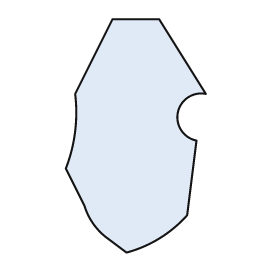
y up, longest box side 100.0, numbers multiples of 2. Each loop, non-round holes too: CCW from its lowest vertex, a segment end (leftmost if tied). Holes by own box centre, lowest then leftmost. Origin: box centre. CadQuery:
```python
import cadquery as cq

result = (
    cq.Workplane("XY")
    .moveTo(-4.0, -50.0)
    .threePointArc((10.0, -44.0), (22.0, -34.0))
    .lineTo(26.0, -2.0)
    .threePointArc((18.0, 10.0), (30.0, 18.0))
    .lineTo(10.0, 50.0)
    .lineTo(-10.0, 50.0)
    .lineTo(-26.0, 18.0)
    .threePointArc((-26.0, 2.0), (-30.0, -14.0))
    .lineTo(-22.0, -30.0)
    .threePointArc((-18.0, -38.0), (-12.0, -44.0))
    .close()
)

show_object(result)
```